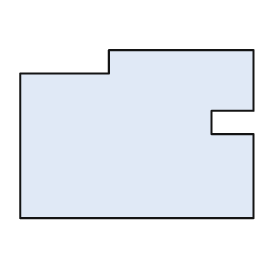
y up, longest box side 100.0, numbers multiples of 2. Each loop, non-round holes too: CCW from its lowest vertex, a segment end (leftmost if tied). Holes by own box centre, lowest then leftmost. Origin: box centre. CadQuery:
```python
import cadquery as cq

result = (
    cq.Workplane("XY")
    .moveTo(-50.0, -36.0)
    .lineTo(50.0, -36.0)
    .lineTo(50.0, 0.0)
    .lineTo(32.0, 0.0)
    .lineTo(32.0, 10.0)
    .lineTo(50.0, 10.0)
    .lineTo(50.0, 36.0)
    .lineTo(-12.0, 36.0)
    .lineTo(-12.0, 26.0)
    .lineTo(-50.0, 26.0)
    .close()
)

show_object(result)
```